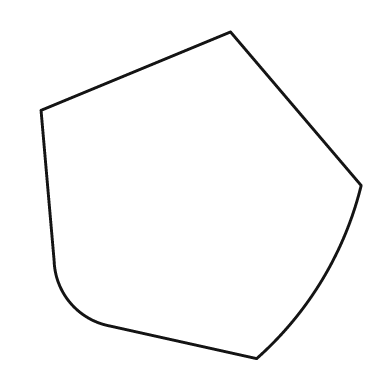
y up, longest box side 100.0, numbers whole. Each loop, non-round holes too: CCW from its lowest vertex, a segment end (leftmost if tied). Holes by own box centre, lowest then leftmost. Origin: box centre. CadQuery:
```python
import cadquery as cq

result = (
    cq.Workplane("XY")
    .moveTo(17.0, -50.0)
    .threePointArc((37.0, -26.0), (49.0, 3.0))
    .lineTo(9.0, 50.0)
    .lineTo(-49.0, 26.0)
    .lineTo(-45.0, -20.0)
    .threePointArc((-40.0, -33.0), (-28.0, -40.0))
    .close()
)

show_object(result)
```